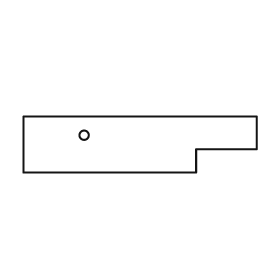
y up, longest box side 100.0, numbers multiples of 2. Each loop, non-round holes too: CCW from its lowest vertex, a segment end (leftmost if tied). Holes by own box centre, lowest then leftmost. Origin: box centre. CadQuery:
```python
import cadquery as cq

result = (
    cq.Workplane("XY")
    .moveTo(-50.0, -12.0)
    .lineTo(24.0, -12.0)
    .lineTo(24.0, -2.0)
    .lineTo(50.0, -2.0)
    .lineTo(50.0, 12.0)
    .lineTo(-50.0, 12.0)
    .close()
    .moveTo(-24.0, 4.0)
    .circle(2.0)
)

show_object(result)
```